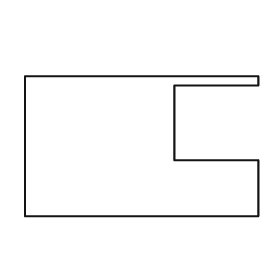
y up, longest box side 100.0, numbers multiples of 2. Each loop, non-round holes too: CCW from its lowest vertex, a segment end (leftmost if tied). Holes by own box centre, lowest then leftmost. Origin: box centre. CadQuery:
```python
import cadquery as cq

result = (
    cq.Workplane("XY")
    .moveTo(-50.0, -30.0)
    .lineTo(50.0, -30.0)
    .lineTo(50.0, -6.0)
    .lineTo(14.0, -6.0)
    .lineTo(14.0, 26.0)
    .lineTo(50.0, 26.0)
    .lineTo(50.0, 30.0)
    .lineTo(-50.0, 30.0)
    .close()
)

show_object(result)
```